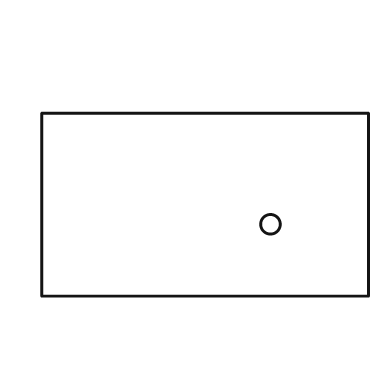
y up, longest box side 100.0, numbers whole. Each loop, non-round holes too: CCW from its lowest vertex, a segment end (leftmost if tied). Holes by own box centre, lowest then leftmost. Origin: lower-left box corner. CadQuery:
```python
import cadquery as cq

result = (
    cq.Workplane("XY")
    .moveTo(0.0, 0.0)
    .lineTo(100.0, 0.0)
    .lineTo(100.0, 56.0)
    .lineTo(0.0, 56.0)
    .close()
    .moveTo(70.0, 22.0)
    .circle(3.0)
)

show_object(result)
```